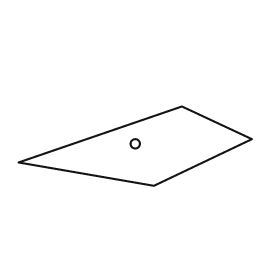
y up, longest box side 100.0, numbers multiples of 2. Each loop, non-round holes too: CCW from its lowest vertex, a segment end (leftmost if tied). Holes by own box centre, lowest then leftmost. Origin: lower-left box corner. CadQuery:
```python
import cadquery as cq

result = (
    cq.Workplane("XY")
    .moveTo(58.0, 0.0)
    .lineTo(100.0, 20.0)
    .lineTo(70.0, 34.0)
    .lineTo(0.0, 10.0)
    .close()
    .moveTo(50.0, 18.0)
    .circle(2.0)
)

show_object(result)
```